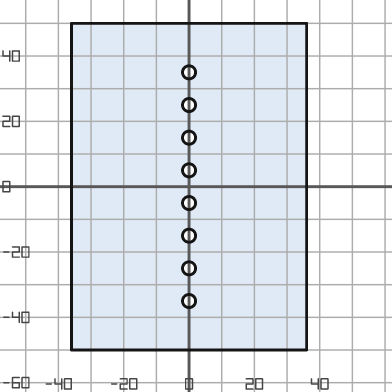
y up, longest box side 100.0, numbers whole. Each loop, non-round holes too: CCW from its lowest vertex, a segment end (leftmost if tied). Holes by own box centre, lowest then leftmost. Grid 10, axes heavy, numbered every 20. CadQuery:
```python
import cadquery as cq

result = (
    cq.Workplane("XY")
    .moveTo(-36.0, -50.0)
    .lineTo(36.0, -50.0)
    .lineTo(36.0, 50.0)
    .lineTo(-36.0, 50.0)
    .close()
    .moveTo(0.0, -35.0)
    .circle(2.0)
    .moveTo(0.0, -25.0)
    .circle(2.0)
    .moveTo(0.0, -15.0)
    .circle(2.0)
    .moveTo(0.0, -5.0)
    .circle(2.0)
    .moveTo(0.0, 5.0)
    .circle(2.0)
    .moveTo(0.0, 15.0)
    .circle(2.0)
    .moveTo(0.0, 25.0)
    .circle(2.0)
    .moveTo(0.0, 35.0)
    .circle(2.0)
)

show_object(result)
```